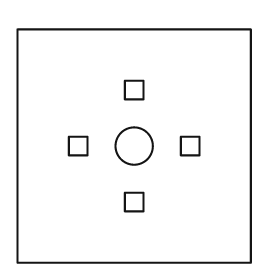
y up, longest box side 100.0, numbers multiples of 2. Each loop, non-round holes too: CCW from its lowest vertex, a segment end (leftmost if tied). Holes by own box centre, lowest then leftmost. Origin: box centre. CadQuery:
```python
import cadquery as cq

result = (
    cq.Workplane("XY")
    .moveTo(-50.0, -50.0)
    .lineTo(50.0, -50.0)
    .lineTo(50.0, 50.0)
    .lineTo(-50.0, 50.0)
    .close()
    .moveTo(-4.0, -28.0)
    .lineTo(4.0, -28.0)
    .lineTo(4.0, -20.0)
    .lineTo(-4.0, -20.0)
    .close()
    .moveTo(-28.0, -4.0)
    .lineTo(-20.0, -4.0)
    .lineTo(-20.0, 4.0)
    .lineTo(-28.0, 4.0)
    .close()
    .moveTo(0.0, 0.0)
    .circle(8.0)
    .moveTo(20.0, -4.0)
    .lineTo(28.0, -4.0)
    .lineTo(28.0, 4.0)
    .lineTo(20.0, 4.0)
    .close()
    .moveTo(-4.0, 20.0)
    .lineTo(4.0, 20.0)
    .lineTo(4.0, 28.0)
    .lineTo(-4.0, 28.0)
    .close()
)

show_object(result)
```